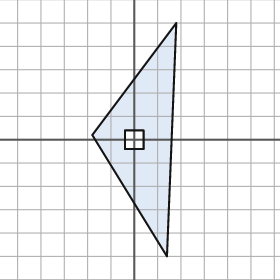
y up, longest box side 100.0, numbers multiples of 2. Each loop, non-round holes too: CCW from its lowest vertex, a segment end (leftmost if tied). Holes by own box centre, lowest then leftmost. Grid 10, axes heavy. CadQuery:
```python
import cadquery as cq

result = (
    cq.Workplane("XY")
    .moveTo(14.0, -50.0)
    .lineTo(18.0, 50.0)
    .lineTo(-18.0, 2.0)
    .close()
    .moveTo(-4.0, -4.0)
    .lineTo(4.0, -4.0)
    .lineTo(4.0, 4.0)
    .lineTo(-4.0, 4.0)
    .close()
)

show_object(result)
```